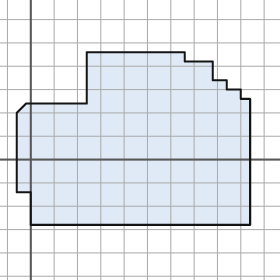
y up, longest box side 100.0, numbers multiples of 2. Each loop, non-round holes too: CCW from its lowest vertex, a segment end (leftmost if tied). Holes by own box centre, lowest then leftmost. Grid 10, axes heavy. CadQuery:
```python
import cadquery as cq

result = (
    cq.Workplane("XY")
    .moveTo(0.0, -28.0)
    .lineTo(94.0, -28.0)
    .lineTo(94.0, 26.0)
    .lineTo(90.0, 26.0)
    .lineTo(90.0, 30.0)
    .lineTo(84.0, 30.0)
    .lineTo(84.0, 34.0)
    .lineTo(78.0, 34.0)
    .lineTo(78.0, 42.0)
    .lineTo(66.0, 42.0)
    .lineTo(66.0, 46.0)
    .lineTo(24.0, 46.0)
    .lineTo(24.0, 24.0)
    .lineTo(-2.0, 24.0)
    .lineTo(-6.0, 20.0)
    .lineTo(-6.0, -14.0)
    .lineTo(0.0, -14.0)
    .close()
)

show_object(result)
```